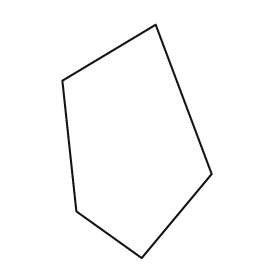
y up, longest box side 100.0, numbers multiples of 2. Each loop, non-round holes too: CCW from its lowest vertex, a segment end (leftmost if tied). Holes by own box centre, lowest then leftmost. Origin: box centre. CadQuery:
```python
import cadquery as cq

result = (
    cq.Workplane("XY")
    .moveTo(2.0, -50.0)
    .lineTo(32.0, -14.0)
    .lineTo(8.0, 50.0)
    .lineTo(-32.0, 26.0)
    .lineTo(-26.0, -30.0)
    .close()
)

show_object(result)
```